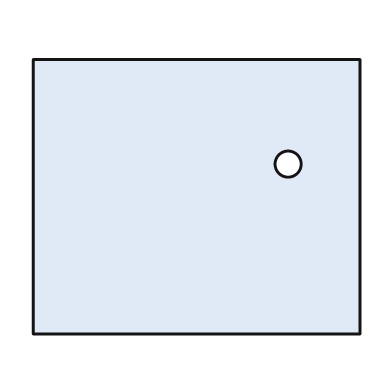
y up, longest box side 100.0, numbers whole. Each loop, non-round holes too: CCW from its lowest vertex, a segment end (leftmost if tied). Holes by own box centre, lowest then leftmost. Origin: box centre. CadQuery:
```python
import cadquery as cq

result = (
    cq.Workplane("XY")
    .moveTo(-50.0, -42.0)
    .lineTo(50.0, -42.0)
    .lineTo(50.0, 42.0)
    .lineTo(-50.0, 42.0)
    .close()
    .moveTo(28.0, 10.0)
    .circle(4.0)
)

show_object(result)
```